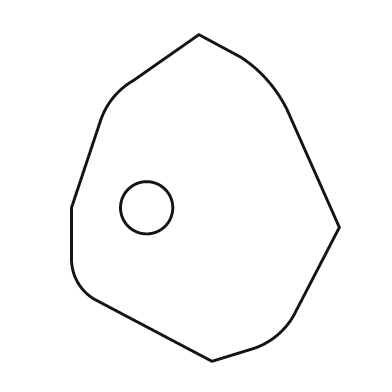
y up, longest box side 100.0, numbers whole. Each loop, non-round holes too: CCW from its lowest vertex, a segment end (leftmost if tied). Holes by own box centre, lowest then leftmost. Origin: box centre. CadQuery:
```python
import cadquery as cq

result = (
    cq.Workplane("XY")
    .moveTo(2.0, -50.0)
    .lineTo(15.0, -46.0)
    .threePointArc((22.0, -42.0), (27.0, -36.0))
    .lineTo(41.0, -9.0)
    .lineTo(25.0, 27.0)
    .threePointArc((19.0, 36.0), (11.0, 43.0))
    .lineTo(-2.0, 50.0)
    .lineTo(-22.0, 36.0)
    .threePointArc((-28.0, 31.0), (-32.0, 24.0))
    .lineTo(-41.0, -3.0)
    .lineTo(-41.0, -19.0)
    .threePointArc((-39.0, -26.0), (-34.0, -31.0))
    .close()
    .moveTo(-18.0, -3.0)
    .circle(8.0)
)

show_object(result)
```